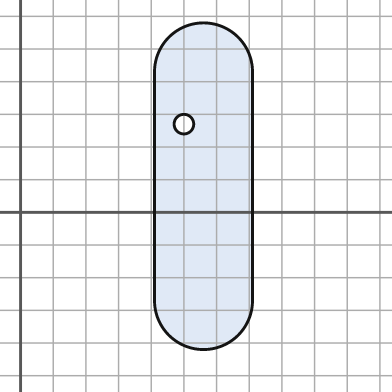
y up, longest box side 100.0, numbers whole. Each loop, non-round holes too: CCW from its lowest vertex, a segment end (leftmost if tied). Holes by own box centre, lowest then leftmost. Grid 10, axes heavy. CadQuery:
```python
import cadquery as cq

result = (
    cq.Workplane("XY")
    .moveTo(41.0, -27.0)
    .threePointArc((56.0, -42.0), (71.0, -27.0))
    .lineTo(71.0, 43.0)
    .threePointArc((56.0, 58.0), (41.0, 43.0))
    .close()
    .moveTo(50.0, 27.0)
    .circle(3.0)
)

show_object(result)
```